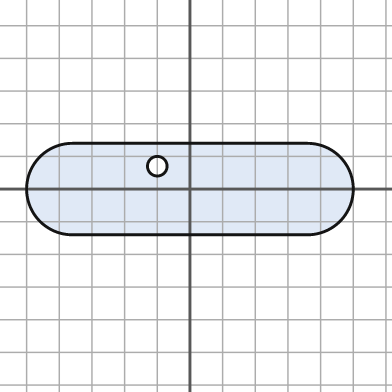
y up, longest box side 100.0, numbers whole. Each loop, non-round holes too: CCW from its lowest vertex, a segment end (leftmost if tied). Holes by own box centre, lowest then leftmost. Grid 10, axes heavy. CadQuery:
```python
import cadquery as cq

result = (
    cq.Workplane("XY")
    .moveTo(-36.0, -14.0)
    .lineTo(36.0, -14.0)
    .threePointArc((50.0, 0.0), (36.0, 14.0))
    .lineTo(-36.0, 14.0)
    .threePointArc((-50.0, 0.0), (-36.0, -14.0))
    .close()
    .moveTo(-10.0, 7.0)
    .circle(3.0)
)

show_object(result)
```